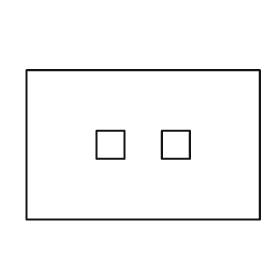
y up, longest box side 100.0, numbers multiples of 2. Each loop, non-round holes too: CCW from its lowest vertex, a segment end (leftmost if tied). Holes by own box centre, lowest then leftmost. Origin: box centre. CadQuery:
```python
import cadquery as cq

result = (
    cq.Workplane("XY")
    .moveTo(-50.0, -32.0)
    .lineTo(50.0, -32.0)
    .lineTo(50.0, 32.0)
    .lineTo(-50.0, 32.0)
    .close()
    .moveTo(-20.0, -6.0)
    .lineTo(-8.0, -6.0)
    .lineTo(-8.0, 6.0)
    .lineTo(-20.0, 6.0)
    .close()
    .moveTo(8.0, -6.0)
    .lineTo(20.0, -6.0)
    .lineTo(20.0, 6.0)
    .lineTo(8.0, 6.0)
    .close()
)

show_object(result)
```